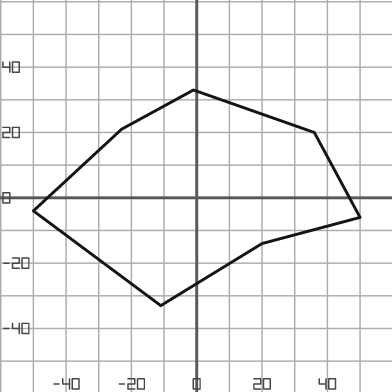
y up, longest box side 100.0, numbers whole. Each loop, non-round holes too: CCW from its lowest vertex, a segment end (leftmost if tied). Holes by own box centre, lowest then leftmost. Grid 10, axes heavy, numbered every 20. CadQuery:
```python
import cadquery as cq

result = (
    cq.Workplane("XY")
    .moveTo(-11.0, -33.0)
    .lineTo(20.0, -14.0)
    .lineTo(50.0, -6.0)
    .lineTo(36.0, 20.0)
    .lineTo(-1.0, 33.0)
    .lineTo(-23.0, 21.0)
    .lineTo(-50.0, -4.0)
    .close()
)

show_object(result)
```